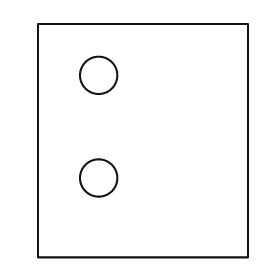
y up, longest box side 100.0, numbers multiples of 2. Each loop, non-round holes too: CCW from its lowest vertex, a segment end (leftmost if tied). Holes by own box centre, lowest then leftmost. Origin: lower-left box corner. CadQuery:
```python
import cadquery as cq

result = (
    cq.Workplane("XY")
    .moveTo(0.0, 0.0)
    .lineTo(90.0, 0.0)
    .lineTo(90.0, 100.0)
    .lineTo(0.0, 100.0)
    .close()
    .moveTo(26.0, 34.0)
    .circle(8.0)
    .moveTo(26.0, 78.0)
    .circle(8.0)
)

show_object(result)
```